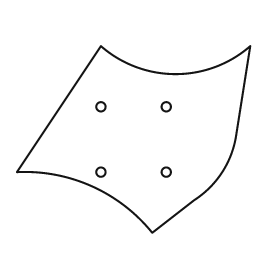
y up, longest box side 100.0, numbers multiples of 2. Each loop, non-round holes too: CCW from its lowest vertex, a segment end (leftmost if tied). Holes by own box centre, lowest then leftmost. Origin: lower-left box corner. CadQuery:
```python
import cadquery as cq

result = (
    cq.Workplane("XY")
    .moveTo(58.0, 0.0)
    .lineTo(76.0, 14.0)
    .threePointArc((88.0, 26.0), (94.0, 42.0))
    .lineTo(100.0, 80.0)
    .threePointArc((68.0, 68.0), (36.0, 80.0))
    .lineTo(0.0, 26.0)
    .threePointArc((32.0, 20.0), (58.0, 0.0))
    .close()
    .moveTo(36.0, 26.0)
    .circle(2.0)
    .moveTo(64.0, 26.0)
    .circle(2.0)
    .moveTo(36.0, 54.0)
    .circle(2.0)
    .moveTo(64.0, 54.0)
    .circle(2.0)
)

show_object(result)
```